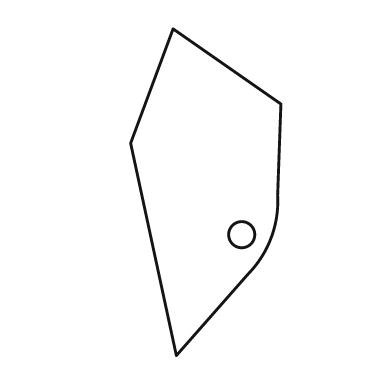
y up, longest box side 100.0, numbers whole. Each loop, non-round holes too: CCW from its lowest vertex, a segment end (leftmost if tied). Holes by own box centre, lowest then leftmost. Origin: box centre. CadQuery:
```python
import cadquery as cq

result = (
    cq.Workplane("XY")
    .moveTo(-9.0, -50.0)
    .lineTo(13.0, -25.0)
    .threePointArc((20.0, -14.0), (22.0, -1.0))
    .lineTo(23.0, 27.0)
    .lineTo(-10.0, 50.0)
    .lineTo(-23.0, 15.0)
    .close()
    .moveTo(11.0, -13.0)
    .circle(4.0)
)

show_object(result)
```